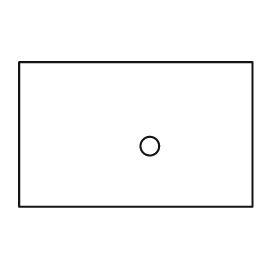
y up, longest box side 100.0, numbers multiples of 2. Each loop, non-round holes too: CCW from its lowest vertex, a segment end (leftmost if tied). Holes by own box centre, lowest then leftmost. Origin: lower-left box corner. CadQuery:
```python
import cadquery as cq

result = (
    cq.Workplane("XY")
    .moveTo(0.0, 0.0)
    .lineTo(100.0, 0.0)
    .lineTo(100.0, 62.0)
    .lineTo(0.0, 62.0)
    .close()
    .moveTo(56.0, 26.0)
    .circle(4.0)
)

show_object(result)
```